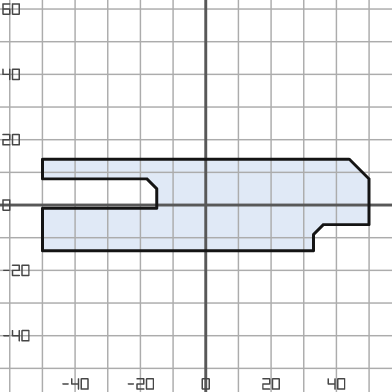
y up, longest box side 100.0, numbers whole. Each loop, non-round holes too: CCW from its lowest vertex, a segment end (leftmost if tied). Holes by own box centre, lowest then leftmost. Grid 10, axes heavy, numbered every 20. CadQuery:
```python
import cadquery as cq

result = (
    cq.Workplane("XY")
    .moveTo(-50.0, -14.0)
    .lineTo(33.0, -14.0)
    .lineTo(33.0, -9.0)
    .lineTo(36.0, -6.0)
    .lineTo(50.0, -6.0)
    .lineTo(50.0, 8.0)
    .lineTo(44.0, 14.0)
    .lineTo(-50.0, 14.0)
    .lineTo(-50.0, 8.0)
    .lineTo(-18.0, 8.0)
    .lineTo(-15.0, 5.0)
    .lineTo(-15.0, -1.0)
    .lineTo(-50.0, -1.0)
    .close()
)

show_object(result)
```